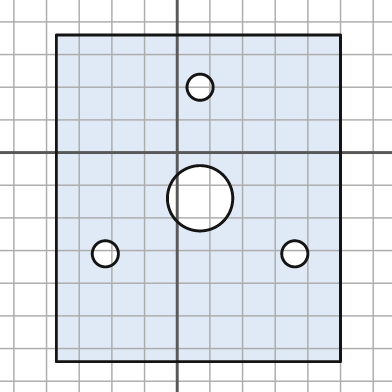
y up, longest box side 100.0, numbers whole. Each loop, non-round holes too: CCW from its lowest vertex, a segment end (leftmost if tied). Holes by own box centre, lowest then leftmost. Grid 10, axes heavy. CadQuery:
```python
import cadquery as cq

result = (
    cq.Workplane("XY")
    .moveTo(-37.0, -64.0)
    .lineTo(50.0, -64.0)
    .lineTo(50.0, 36.0)
    .lineTo(-37.0, 36.0)
    .close()
    .moveTo(-22.0, -31.0)
    .circle(4.0)
    .moveTo(36.0, -31.0)
    .circle(4.0)
    .moveTo(7.0, -14.0)
    .circle(10.0)
    .moveTo(7.0, 20.0)
    .circle(4.0)
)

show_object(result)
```